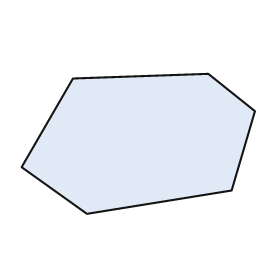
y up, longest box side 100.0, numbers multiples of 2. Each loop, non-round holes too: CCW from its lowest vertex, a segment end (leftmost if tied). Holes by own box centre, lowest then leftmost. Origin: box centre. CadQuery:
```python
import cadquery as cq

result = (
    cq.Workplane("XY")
    .moveTo(-22.0, -30.0)
    .lineTo(40.0, -20.0)
    .lineTo(50.0, 14.0)
    .lineTo(30.0, 30.0)
    .lineTo(-28.0, 28.0)
    .lineTo(-50.0, -10.0)
    .close()
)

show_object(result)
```